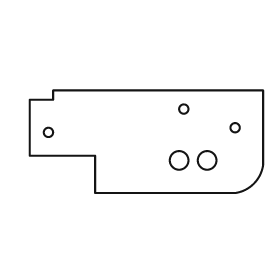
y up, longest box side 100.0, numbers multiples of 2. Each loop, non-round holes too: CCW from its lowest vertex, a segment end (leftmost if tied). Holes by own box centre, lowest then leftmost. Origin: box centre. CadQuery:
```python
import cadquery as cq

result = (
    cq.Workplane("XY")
    .moveTo(-22.0, -22.0)
    .lineTo(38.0, -22.0)
    .threePointArc((46.0, -18.0), (50.0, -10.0))
    .lineTo(50.0, 22.0)
    .lineTo(-40.0, 22.0)
    .lineTo(-40.0, 18.0)
    .lineTo(-50.0, 18.0)
    .lineTo(-50.0, -6.0)
    .lineTo(-22.0, -6.0)
    .close()
    .moveTo(14.0, -8.0)
    .circle(4.0)
    .moveTo(26.0, -8.0)
    .circle(4.0)
    .moveTo(-42.0, 4.0)
    .circle(2.0)
    .moveTo(38.0, 6.0)
    .circle(2.0)
    .moveTo(16.0, 14.0)
    .circle(2.0)
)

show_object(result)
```